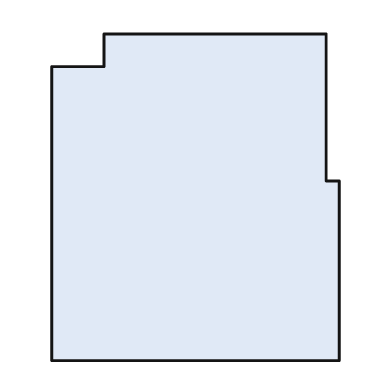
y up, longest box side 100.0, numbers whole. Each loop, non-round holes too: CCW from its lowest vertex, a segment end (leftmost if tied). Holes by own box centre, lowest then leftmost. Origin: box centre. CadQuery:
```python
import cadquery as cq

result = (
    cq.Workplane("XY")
    .moveTo(-44.0, -50.0)
    .lineTo(44.0, -50.0)
    .lineTo(44.0, 5.0)
    .lineTo(40.0, 5.0)
    .lineTo(40.0, 50.0)
    .lineTo(-28.0, 50.0)
    .lineTo(-28.0, 40.0)
    .lineTo(-44.0, 40.0)
    .close()
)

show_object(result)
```